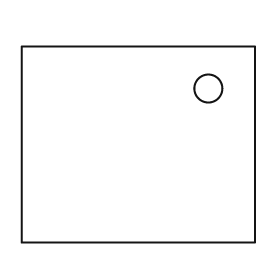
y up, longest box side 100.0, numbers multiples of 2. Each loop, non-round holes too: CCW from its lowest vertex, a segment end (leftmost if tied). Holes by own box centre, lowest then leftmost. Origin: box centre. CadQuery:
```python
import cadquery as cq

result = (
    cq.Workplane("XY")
    .moveTo(-50.0, -42.0)
    .lineTo(50.0, -42.0)
    .lineTo(50.0, 42.0)
    .lineTo(-50.0, 42.0)
    .close()
    .moveTo(30.0, 24.0)
    .circle(6.0)
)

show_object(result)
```